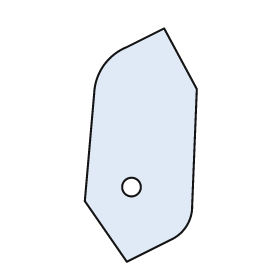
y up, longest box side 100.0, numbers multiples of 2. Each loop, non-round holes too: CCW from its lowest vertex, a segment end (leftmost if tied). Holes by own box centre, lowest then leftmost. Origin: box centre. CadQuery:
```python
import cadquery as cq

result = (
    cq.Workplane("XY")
    .moveTo(-6.0, -50.0)
    .lineTo(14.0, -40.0)
    .threePointArc((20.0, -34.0), (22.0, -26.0))
    .lineTo(24.0, 24.0)
    .lineTo(10.0, 50.0)
    .lineTo(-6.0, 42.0)
    .threePointArc((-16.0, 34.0), (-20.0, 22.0))
    .lineTo(-24.0, -24.0)
    .close()
    .moveTo(-4.0, -18.0)
    .circle(4.0)
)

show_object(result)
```